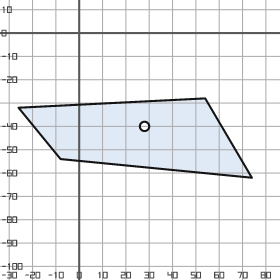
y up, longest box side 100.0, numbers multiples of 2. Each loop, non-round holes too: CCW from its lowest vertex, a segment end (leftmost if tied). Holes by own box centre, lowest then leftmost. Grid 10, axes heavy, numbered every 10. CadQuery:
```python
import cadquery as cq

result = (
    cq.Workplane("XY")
    .moveTo(74.0, -62.0)
    .lineTo(54.0, -28.0)
    .lineTo(-26.0, -32.0)
    .lineTo(-8.0, -54.0)
    .close()
    .moveTo(28.0, -40.0)
    .circle(2.0)
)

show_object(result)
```